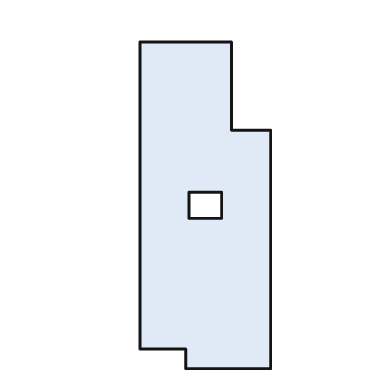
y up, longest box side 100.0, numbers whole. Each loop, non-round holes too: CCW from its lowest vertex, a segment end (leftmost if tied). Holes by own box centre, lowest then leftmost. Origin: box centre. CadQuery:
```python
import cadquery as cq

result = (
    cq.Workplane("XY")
    .moveTo(-6.0, -50.0)
    .lineTo(20.0, -50.0)
    .lineTo(20.0, 23.0)
    .lineTo(8.0, 23.0)
    .lineTo(8.0, 50.0)
    .lineTo(-20.0, 50.0)
    .lineTo(-20.0, -44.0)
    .lineTo(-6.0, -44.0)
    .close()
    .moveTo(-5.0, -4.0)
    .lineTo(5.0, -4.0)
    .lineTo(5.0, 4.0)
    .lineTo(-5.0, 4.0)
    .close()
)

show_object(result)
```